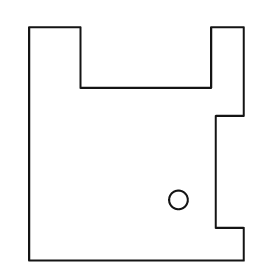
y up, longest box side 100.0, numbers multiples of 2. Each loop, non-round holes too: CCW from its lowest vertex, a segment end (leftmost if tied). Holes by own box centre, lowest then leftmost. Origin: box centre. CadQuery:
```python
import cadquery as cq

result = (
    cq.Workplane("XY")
    .moveTo(-46.0, -50.0)
    .lineTo(46.0, -50.0)
    .lineTo(46.0, -36.0)
    .lineTo(34.0, -36.0)
    .lineTo(34.0, 12.0)
    .lineTo(46.0, 12.0)
    .lineTo(46.0, 50.0)
    .lineTo(32.0, 50.0)
    .lineTo(32.0, 24.0)
    .lineTo(-24.0, 24.0)
    .lineTo(-24.0, 50.0)
    .lineTo(-46.0, 50.0)
    .close()
    .moveTo(18.0, -24.0)
    .circle(4.0)
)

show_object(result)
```